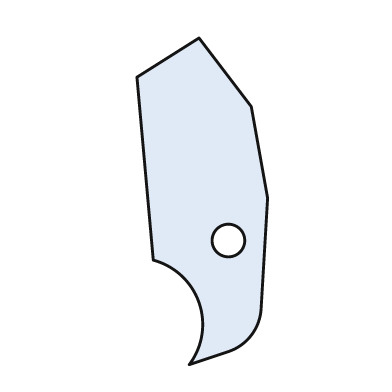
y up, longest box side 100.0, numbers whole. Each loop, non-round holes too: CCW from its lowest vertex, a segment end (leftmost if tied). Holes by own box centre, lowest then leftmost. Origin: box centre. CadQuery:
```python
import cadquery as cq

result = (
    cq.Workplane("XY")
    .moveTo(-4.0, -50.0)
    .lineTo(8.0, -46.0)
    .threePointArc((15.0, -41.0), (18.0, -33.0))
    .lineTo(20.0, 1.0)
    .lineTo(15.0, 29.0)
    .lineTo(-1.0, 50.0)
    .lineTo(-20.0, 38.0)
    .lineTo(-15.0, -18.0)
    .threePointArc((-1.0, -31.0), (-4.0, -50.0))
    .close()
    .moveTo(8.0, -12.0)
    .circle(5.0)
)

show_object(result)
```